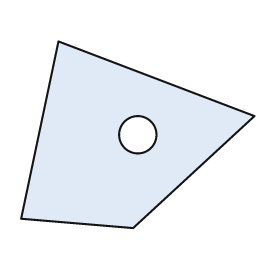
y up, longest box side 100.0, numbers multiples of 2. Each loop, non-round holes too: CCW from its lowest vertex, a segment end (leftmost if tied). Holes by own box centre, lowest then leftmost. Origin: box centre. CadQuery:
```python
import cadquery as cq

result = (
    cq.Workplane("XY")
    .moveTo(-2.0, -40.0)
    .lineTo(50.0, 8.0)
    .lineTo(-34.0, 40.0)
    .lineTo(-50.0, -36.0)
    .close()
    .moveTo(0.0, 0.0)
    .circle(8.0)
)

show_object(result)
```